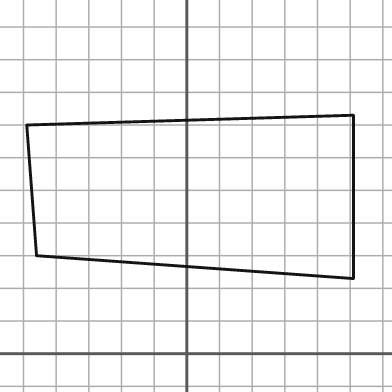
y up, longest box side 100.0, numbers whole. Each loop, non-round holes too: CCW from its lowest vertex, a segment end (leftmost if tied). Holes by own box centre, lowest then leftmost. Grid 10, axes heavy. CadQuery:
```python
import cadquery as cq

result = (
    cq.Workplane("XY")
    .moveTo(51.0, 23.0)
    .lineTo(51.0, 73.0)
    .lineTo(-49.0, 70.0)
    .lineTo(-46.0, 30.0)
    .close()
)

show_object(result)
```